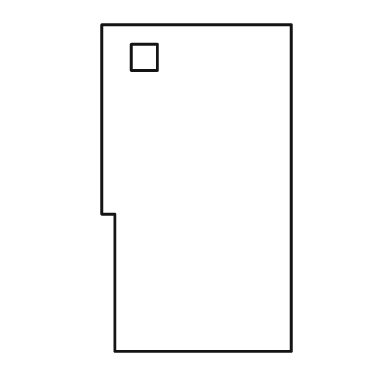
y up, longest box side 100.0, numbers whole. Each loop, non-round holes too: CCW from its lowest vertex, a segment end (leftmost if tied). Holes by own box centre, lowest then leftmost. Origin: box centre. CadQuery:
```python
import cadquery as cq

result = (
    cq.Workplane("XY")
    .moveTo(-25.0, -50.0)
    .lineTo(29.0, -50.0)
    .lineTo(29.0, 50.0)
    .lineTo(-29.0, 50.0)
    .lineTo(-29.0, -8.0)
    .lineTo(-25.0, -8.0)
    .close()
    .moveTo(-20.0, 36.0)
    .lineTo(-12.0, 36.0)
    .lineTo(-12.0, 44.0)
    .lineTo(-20.0, 44.0)
    .close()
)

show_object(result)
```